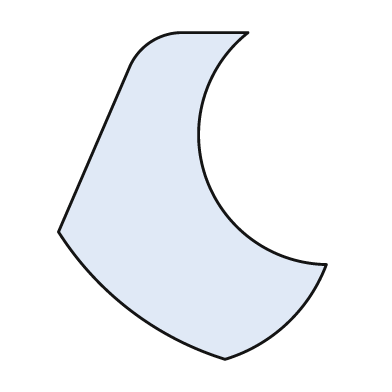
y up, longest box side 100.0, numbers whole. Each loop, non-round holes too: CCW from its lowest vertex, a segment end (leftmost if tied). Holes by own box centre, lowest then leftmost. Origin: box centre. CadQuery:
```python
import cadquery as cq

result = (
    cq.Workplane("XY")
    .moveTo(10.0, -50.0)
    .threePointArc((29.0, -39.0), (41.0, -21.0))
    .threePointArc((4.0, 6.0), (17.0, 50.0))
    .lineTo(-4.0, 50.0)
    .threePointArc((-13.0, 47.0), (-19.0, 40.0))
    .lineTo(-41.0, -11.0)
    .threePointArc((-19.0, -35.0), (10.0, -50.0))
    .close()
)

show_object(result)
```